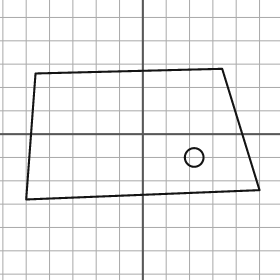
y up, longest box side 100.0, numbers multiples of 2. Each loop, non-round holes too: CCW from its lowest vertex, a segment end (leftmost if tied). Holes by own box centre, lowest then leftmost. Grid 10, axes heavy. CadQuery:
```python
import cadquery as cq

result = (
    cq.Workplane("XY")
    .moveTo(-50.0, -28.0)
    .lineTo(50.0, -24.0)
    .lineTo(34.0, 28.0)
    .lineTo(-46.0, 26.0)
    .close()
    .moveTo(22.0, -10.0)
    .circle(4.0)
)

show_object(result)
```